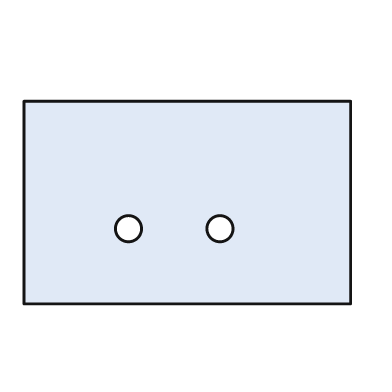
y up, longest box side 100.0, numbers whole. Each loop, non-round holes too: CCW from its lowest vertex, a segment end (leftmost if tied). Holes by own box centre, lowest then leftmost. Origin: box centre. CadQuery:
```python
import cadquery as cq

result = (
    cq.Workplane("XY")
    .moveTo(-50.0, -31.0)
    .lineTo(50.0, -31.0)
    .lineTo(50.0, 31.0)
    .lineTo(-50.0, 31.0)
    .close()
    .moveTo(-18.0, -8.0)
    .circle(4.0)
    .moveTo(10.0, -8.0)
    .circle(4.0)
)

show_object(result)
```